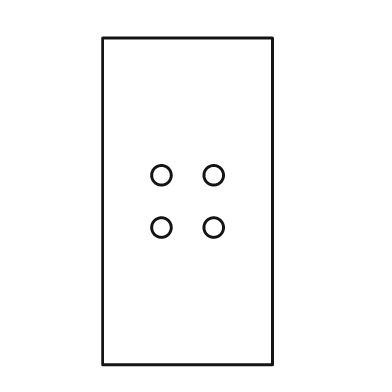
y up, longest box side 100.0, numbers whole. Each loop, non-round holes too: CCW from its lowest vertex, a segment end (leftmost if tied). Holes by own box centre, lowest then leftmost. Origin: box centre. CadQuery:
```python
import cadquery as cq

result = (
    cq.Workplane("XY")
    .moveTo(-26.0, -50.0)
    .lineTo(26.0, -50.0)
    .lineTo(26.0, 50.0)
    .lineTo(-26.0, 50.0)
    .close()
    .moveTo(-8.0, -8.0)
    .circle(3.0)
    .moveTo(8.0, -8.0)
    .circle(3.0)
    .moveTo(-8.0, 8.0)
    .circle(3.0)
    .moveTo(8.0, 8.0)
    .circle(3.0)
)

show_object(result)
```